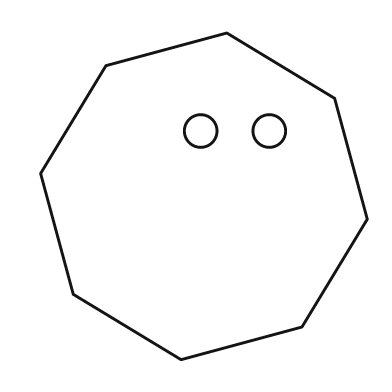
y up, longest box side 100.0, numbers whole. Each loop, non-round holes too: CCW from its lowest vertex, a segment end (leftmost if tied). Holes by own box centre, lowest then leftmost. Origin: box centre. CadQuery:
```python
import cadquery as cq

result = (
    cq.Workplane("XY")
    .moveTo(-7.0, -50.0)
    .lineTo(30.0, -40.0)
    .lineTo(50.0, -7.0)
    .lineTo(40.0, 30.0)
    .lineTo(7.0, 50.0)
    .lineTo(-30.0, 40.0)
    .lineTo(-50.0, 7.0)
    .lineTo(-40.0, -30.0)
    .close()
    .moveTo(-1.0, 20.0)
    .circle(5.0)
    .moveTo(20.0, 20.0)
    .circle(5.0)
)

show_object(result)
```